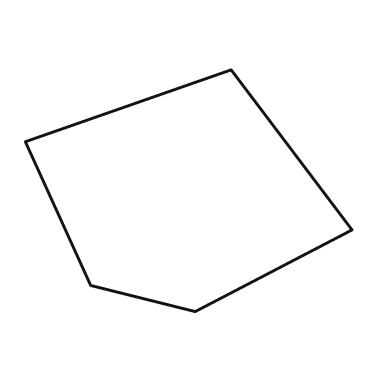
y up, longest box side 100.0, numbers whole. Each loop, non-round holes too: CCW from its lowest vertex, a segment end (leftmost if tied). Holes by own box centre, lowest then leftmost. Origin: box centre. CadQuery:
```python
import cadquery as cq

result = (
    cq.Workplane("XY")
    .moveTo(2.0, -37.0)
    .lineTo(50.0, -12.0)
    .lineTo(13.0, 37.0)
    .lineTo(-50.0, 15.0)
    .lineTo(-30.0, -29.0)
    .close()
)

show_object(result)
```